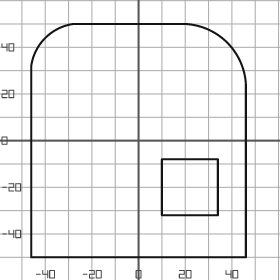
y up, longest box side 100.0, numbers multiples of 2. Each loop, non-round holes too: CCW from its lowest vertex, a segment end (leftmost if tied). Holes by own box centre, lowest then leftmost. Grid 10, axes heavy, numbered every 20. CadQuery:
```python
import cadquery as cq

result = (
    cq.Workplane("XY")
    .moveTo(-46.0, -50.0)
    .lineTo(46.0, -50.0)
    .lineTo(46.0, 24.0)
    .threePointArc((38.0, 42.0), (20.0, 50.0))
    .lineTo(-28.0, 50.0)
    .threePointArc((-40.0, 44.0), (-46.0, 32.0))
    .close()
    .moveTo(10.0, -32.0)
    .lineTo(34.0, -32.0)
    .lineTo(34.0, -8.0)
    .lineTo(10.0, -8.0)
    .close()
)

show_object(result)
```